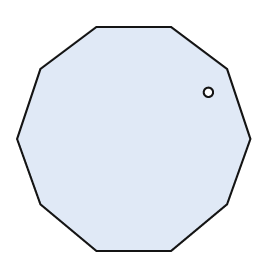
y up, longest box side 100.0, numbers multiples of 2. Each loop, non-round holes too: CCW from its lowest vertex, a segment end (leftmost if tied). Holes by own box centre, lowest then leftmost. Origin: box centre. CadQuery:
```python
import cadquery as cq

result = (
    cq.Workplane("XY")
    .moveTo(-16.0, -48.0)
    .lineTo(16.0, -48.0)
    .lineTo(40.0, -28.0)
    .lineTo(50.0, 0.0)
    .lineTo(40.0, 30.0)
    .lineTo(16.0, 48.0)
    .lineTo(-16.0, 48.0)
    .lineTo(-40.0, 30.0)
    .lineTo(-50.0, 0.0)
    .lineTo(-40.0, -28.0)
    .close()
    .moveTo(32.0, 20.0)
    .circle(2.0)
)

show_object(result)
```